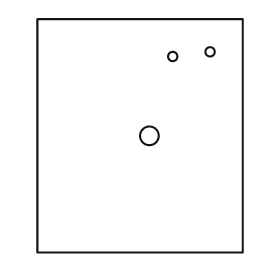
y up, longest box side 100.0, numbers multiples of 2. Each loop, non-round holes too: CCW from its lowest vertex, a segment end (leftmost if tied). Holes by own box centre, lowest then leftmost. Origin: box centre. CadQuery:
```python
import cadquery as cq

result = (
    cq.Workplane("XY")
    .moveTo(-44.0, -50.0)
    .lineTo(44.0, -50.0)
    .lineTo(44.0, 50.0)
    .lineTo(-44.0, 50.0)
    .close()
    .moveTo(4.0, 0.0)
    .circle(4.0)
    .moveTo(14.0, 34.0)
    .circle(2.0)
    .moveTo(30.0, 36.0)
    .circle(2.0)
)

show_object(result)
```